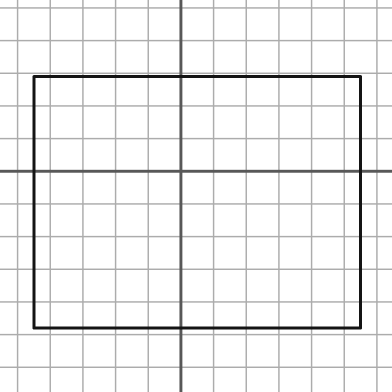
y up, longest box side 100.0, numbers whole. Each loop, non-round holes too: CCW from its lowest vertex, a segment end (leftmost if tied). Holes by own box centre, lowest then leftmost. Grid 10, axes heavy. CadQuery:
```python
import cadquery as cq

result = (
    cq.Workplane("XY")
    .moveTo(-45.0, -48.0)
    .lineTo(55.0, -48.0)
    .lineTo(55.0, 29.0)
    .lineTo(-45.0, 29.0)
    .close()
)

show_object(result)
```